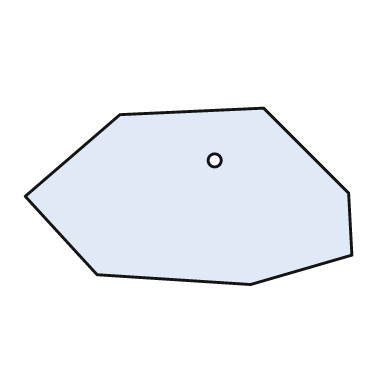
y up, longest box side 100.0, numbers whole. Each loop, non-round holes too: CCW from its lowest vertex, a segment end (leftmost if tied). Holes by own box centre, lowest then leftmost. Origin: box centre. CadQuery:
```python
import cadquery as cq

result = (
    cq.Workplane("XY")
    .moveTo(19.0, -27.0)
    .lineTo(50.0, -18.0)
    .lineTo(49.0, 1.0)
    .lineTo(23.0, 27.0)
    .lineTo(-21.0, 25.0)
    .lineTo(-50.0, 0.0)
    .lineTo(-28.0, -24.0)
    .close()
    .moveTo(8.0, 11.0)
    .circle(2.0)
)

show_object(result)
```